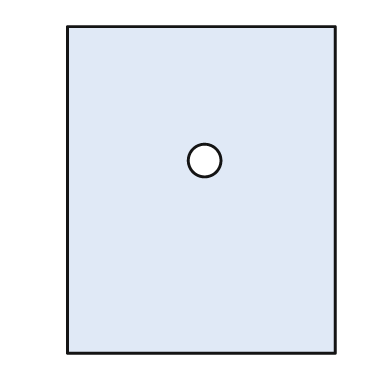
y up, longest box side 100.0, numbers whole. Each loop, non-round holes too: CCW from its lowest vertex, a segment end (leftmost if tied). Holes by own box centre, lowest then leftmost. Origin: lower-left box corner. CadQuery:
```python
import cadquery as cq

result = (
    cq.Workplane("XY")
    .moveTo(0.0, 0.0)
    .lineTo(82.0, 0.0)
    .lineTo(82.0, 100.0)
    .lineTo(0.0, 100.0)
    .close()
    .moveTo(42.0, 59.0)
    .circle(5.0)
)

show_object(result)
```